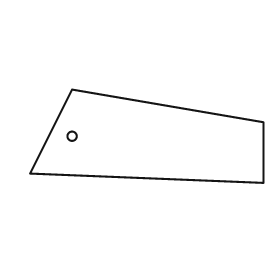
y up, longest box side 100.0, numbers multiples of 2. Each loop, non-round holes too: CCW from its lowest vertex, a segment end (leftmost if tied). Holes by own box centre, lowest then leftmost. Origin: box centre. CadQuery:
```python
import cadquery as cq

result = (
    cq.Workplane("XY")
    .moveTo(50.0, -20.0)
    .lineTo(50.0, 6.0)
    .lineTo(-32.0, 20.0)
    .lineTo(-50.0, -16.0)
    .close()
    .moveTo(-32.0, 0.0)
    .circle(2.0)
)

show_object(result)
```